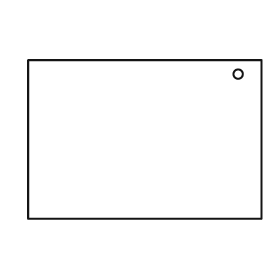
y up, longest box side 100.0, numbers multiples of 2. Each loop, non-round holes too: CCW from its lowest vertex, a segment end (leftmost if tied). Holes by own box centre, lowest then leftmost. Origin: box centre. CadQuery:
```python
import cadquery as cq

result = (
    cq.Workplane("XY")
    .moveTo(-50.0, -34.0)
    .lineTo(50.0, -34.0)
    .lineTo(50.0, 34.0)
    .lineTo(-50.0, 34.0)
    .close()
    .moveTo(40.0, 28.0)
    .circle(2.0)
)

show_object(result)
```